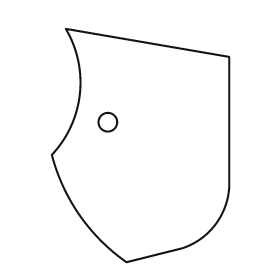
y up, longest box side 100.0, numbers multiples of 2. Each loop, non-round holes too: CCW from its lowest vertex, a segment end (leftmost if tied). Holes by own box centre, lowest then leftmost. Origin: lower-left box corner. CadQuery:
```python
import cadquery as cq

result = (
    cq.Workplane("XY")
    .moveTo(32.0, 0.0)
    .lineTo(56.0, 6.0)
    .threePointArc((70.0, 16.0), (76.0, 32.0))
    .lineTo(76.0, 88.0)
    .lineTo(6.0, 100.0)
    .threePointArc((12.0, 72.0), (0.0, 46.0))
    .threePointArc((12.0, 20.0), (32.0, 0.0))
    .close()
    .moveTo(24.0, 60.0)
    .circle(4.0)
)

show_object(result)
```